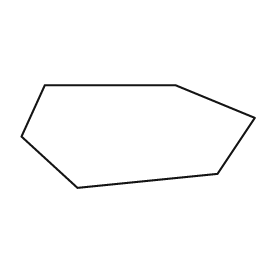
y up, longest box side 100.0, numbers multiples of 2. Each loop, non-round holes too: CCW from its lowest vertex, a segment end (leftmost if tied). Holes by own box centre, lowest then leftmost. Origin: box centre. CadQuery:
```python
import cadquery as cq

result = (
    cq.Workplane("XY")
    .moveTo(-26.0, -22.0)
    .lineTo(34.0, -16.0)
    .lineTo(50.0, 8.0)
    .lineTo(16.0, 22.0)
    .lineTo(-40.0, 22.0)
    .lineTo(-50.0, 0.0)
    .close()
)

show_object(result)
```